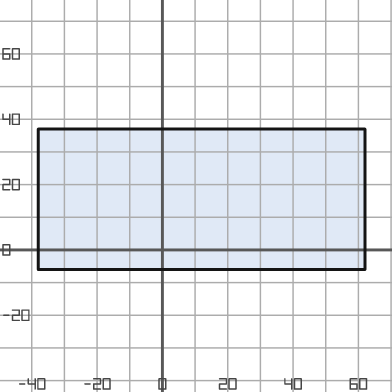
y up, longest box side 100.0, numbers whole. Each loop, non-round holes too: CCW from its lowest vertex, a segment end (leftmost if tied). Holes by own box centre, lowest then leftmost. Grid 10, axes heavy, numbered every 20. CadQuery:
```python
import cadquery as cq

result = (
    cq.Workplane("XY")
    .moveTo(-38.0, -6.0)
    .lineTo(62.0, -6.0)
    .lineTo(62.0, 37.0)
    .lineTo(-38.0, 37.0)
    .close()
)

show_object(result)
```